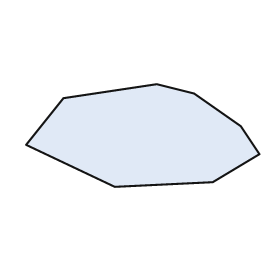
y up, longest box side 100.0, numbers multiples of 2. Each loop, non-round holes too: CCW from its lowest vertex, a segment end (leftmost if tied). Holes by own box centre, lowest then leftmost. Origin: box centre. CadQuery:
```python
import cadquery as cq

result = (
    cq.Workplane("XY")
    .moveTo(-12.0, -22.0)
    .lineTo(30.0, -20.0)
    .lineTo(50.0, -8.0)
    .lineTo(42.0, 4.0)
    .lineTo(22.0, 18.0)
    .lineTo(6.0, 22.0)
    .lineTo(-34.0, 16.0)
    .lineTo(-50.0, -4.0)
    .close()
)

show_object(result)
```